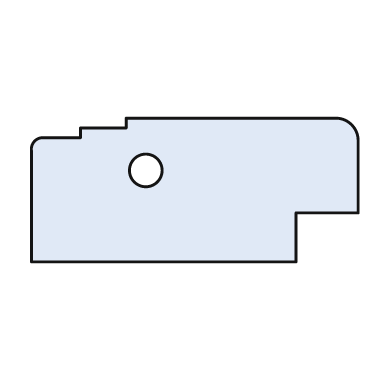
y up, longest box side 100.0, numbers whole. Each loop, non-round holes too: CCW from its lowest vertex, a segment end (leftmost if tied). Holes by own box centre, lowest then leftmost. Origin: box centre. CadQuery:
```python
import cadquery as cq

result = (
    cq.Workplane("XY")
    .moveTo(-50.0, -22.0)
    .lineTo(31.0, -22.0)
    .lineTo(31.0, -7.0)
    .lineTo(50.0, -7.0)
    .lineTo(50.0, 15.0)
    .threePointArc((48.0, 20.0), (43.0, 22.0))
    .lineTo(-21.0, 22.0)
    .lineTo(-21.0, 19.0)
    .lineTo(-35.0, 19.0)
    .lineTo(-35.0, 16.0)
    .lineTo(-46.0, 16.0)
    .threePointArc((-49.0, 15.0), (-50.0, 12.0))
    .close()
    .moveTo(-15.0, 6.0)
    .circle(5.0)
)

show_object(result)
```